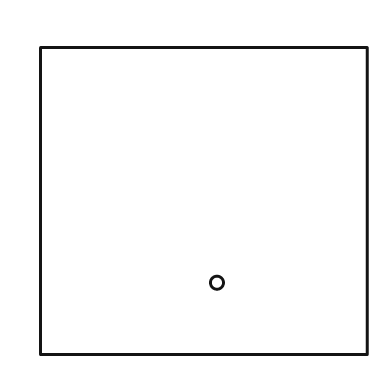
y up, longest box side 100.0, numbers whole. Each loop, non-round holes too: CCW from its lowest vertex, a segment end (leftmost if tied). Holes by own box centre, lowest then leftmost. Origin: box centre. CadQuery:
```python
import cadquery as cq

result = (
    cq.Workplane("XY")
    .moveTo(-50.0, -47.0)
    .lineTo(50.0, -47.0)
    .lineTo(50.0, 47.0)
    .lineTo(-50.0, 47.0)
    .close()
    .moveTo(4.0, -25.0)
    .circle(2.0)
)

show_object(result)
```